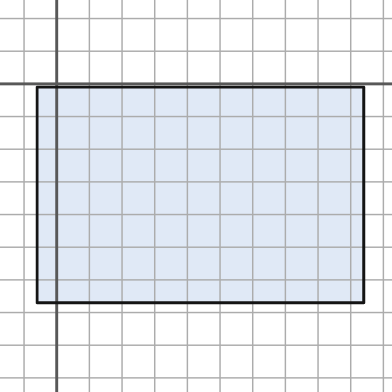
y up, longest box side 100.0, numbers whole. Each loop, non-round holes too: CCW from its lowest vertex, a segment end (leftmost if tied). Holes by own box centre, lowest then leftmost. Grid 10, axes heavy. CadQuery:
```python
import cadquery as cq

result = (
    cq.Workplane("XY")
    .moveTo(-6.0, -67.0)
    .lineTo(94.0, -67.0)
    .lineTo(94.0, -1.0)
    .lineTo(-6.0, -1.0)
    .close()
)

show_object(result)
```